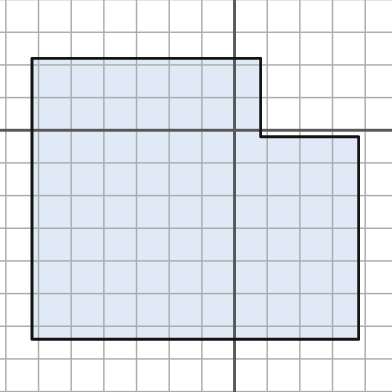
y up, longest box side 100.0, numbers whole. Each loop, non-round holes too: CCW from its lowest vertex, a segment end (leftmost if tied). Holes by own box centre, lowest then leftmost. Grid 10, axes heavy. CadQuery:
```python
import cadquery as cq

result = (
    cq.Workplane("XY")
    .moveTo(-62.0, -64.0)
    .lineTo(38.0, -64.0)
    .lineTo(38.0, -2.0)
    .lineTo(8.0, -2.0)
    .lineTo(8.0, 22.0)
    .lineTo(-62.0, 22.0)
    .close()
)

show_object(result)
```